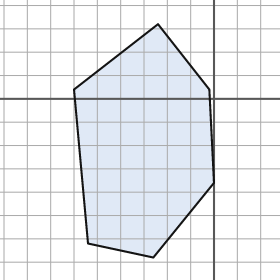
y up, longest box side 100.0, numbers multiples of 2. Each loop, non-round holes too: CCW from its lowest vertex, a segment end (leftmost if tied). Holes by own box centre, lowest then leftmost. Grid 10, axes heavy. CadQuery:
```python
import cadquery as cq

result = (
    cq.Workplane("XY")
    .moveTo(-26.0, -68.0)
    .lineTo(0.0, -36.0)
    .lineTo(-2.0, 4.0)
    .lineTo(-24.0, 32.0)
    .lineTo(-60.0, 4.0)
    .lineTo(-54.0, -62.0)
    .close()
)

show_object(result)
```